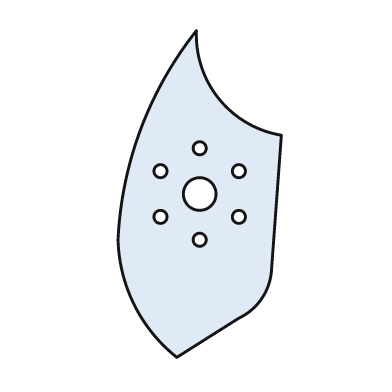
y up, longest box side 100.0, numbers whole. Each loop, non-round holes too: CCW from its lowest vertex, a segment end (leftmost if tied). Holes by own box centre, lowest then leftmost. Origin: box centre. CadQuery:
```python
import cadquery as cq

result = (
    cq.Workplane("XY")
    .moveTo(-7.0, -50.0)
    .lineTo(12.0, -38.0)
    .threePointArc((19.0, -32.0), (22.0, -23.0))
    .lineTo(25.0, 18.0)
    .threePointArc((6.0, 29.0), (-1.0, 50.0))
    .threePointArc((-18.0, 20.0), (-25.0, -14.0))
    .threePointArc((-20.0, -34.0), (-7.0, -50.0))
    .close()
    .moveTo(0.0, -14.0)
    .circle(2.0)
    .moveTo(-12.0, -7.0)
    .circle(2.0)
    .moveTo(12.0, -7.0)
    .circle(2.0)
    .moveTo(0.0, 0.0)
    .circle(5.0)
    .moveTo(-12.0, 7.0)
    .circle(2.0)
    .moveTo(12.0, 7.0)
    .circle(2.0)
    .moveTo(0.0, 14.0)
    .circle(2.0)
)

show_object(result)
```